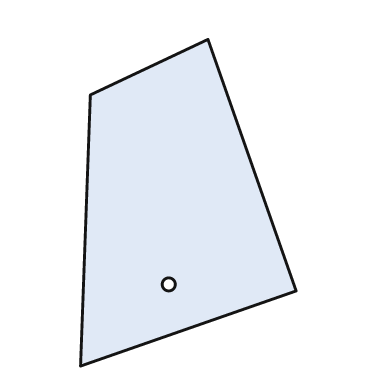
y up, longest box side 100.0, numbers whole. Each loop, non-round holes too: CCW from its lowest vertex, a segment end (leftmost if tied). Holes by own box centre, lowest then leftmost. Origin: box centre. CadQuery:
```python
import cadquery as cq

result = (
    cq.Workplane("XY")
    .moveTo(-33.0, -50.0)
    .lineTo(33.0, -27.0)
    .lineTo(6.0, 50.0)
    .lineTo(-30.0, 33.0)
    .close()
    .moveTo(-6.0, -25.0)
    .circle(2.0)
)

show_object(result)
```